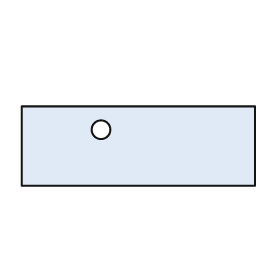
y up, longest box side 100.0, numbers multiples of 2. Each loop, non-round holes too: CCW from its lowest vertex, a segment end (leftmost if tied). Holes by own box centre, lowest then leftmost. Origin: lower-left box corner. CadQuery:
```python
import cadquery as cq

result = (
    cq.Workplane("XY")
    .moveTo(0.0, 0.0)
    .lineTo(100.0, 0.0)
    .lineTo(100.0, 34.0)
    .lineTo(0.0, 34.0)
    .close()
    .moveTo(34.0, 24.0)
    .circle(4.0)
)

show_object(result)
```